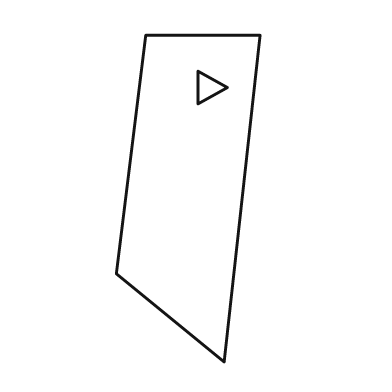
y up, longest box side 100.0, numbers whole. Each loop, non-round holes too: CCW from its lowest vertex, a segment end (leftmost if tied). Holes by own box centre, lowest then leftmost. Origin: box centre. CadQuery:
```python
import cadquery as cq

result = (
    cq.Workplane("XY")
    .moveTo(11.0, -50.0)
    .lineTo(22.0, 50.0)
    .lineTo(-13.0, 50.0)
    .lineTo(-22.0, -23.0)
    .close()
    .moveTo(3.0, 29.0)
    .lineTo(12.0, 34.0)
    .lineTo(3.0, 39.0)
    .close()
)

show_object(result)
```